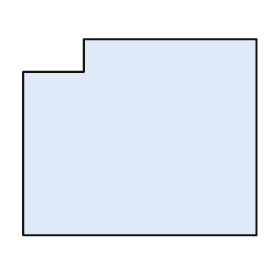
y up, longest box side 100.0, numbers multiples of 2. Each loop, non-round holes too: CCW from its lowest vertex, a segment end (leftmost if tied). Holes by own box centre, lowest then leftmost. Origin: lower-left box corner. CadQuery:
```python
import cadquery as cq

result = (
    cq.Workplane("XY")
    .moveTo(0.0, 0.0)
    .lineTo(100.0, 0.0)
    .lineTo(100.0, 84.0)
    .lineTo(26.0, 84.0)
    .lineTo(26.0, 70.0)
    .lineTo(0.0, 70.0)
    .close()
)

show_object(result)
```